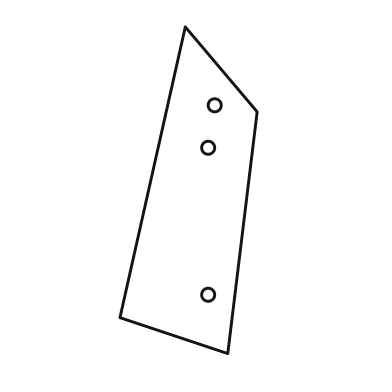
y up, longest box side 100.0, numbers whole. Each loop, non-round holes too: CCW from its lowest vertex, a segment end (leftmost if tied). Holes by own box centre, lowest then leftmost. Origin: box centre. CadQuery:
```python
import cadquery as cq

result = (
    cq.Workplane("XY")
    .moveTo(12.0, -50.0)
    .lineTo(21.0, 24.0)
    .lineTo(-1.0, 50.0)
    .lineTo(-21.0, -39.0)
    .close()
    .moveTo(6.0, -32.0)
    .circle(2.0)
    .moveTo(6.0, 13.0)
    .circle(2.0)
    .moveTo(8.0, 26.0)
    .circle(2.0)
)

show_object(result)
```